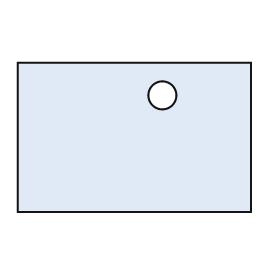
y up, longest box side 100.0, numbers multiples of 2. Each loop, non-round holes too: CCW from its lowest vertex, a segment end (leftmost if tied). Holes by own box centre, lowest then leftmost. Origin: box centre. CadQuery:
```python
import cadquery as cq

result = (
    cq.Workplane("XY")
    .moveTo(-50.0, -32.0)
    .lineTo(50.0, -32.0)
    .lineTo(50.0, 32.0)
    .lineTo(-50.0, 32.0)
    .close()
    .moveTo(12.0, 18.0)
    .circle(6.0)
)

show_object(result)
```